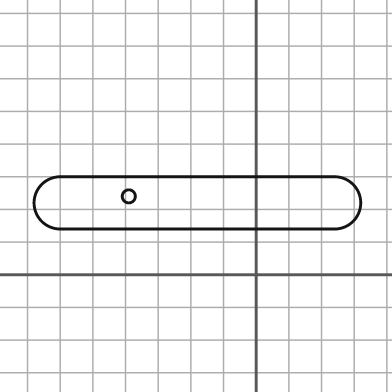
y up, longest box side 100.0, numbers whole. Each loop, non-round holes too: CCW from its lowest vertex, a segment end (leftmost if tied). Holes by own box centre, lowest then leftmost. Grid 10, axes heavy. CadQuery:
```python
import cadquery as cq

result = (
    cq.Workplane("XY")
    .moveTo(-60.0, 14.0)
    .lineTo(24.0, 14.0)
    .threePointArc((32.0, 22.0), (24.0, 30.0))
    .lineTo(-60.0, 30.0)
    .threePointArc((-68.0, 22.0), (-60.0, 14.0))
    .close()
    .moveTo(-39.0, 24.0)
    .circle(2.0)
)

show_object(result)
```